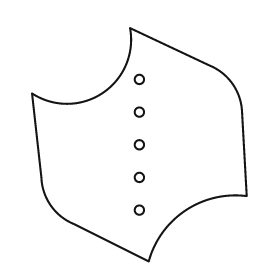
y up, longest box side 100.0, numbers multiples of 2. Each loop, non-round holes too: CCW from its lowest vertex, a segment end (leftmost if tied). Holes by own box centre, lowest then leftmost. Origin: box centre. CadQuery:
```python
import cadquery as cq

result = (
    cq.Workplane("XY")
    .moveTo(4.0, -50.0)
    .threePointArc((20.0, -28.0), (46.0, -22.0))
    .lineTo(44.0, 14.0)
    .threePointArc((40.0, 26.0), (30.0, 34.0))
    .lineTo(-4.0, 50.0)
    .threePointArc((-16.0, 22.0), (-46.0, 22.0))
    .lineTo(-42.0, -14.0)
    .threePointArc((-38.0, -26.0), (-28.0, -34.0))
    .close()
    .moveTo(0.0, -28.0)
    .circle(2.0)
    .moveTo(0.0, -14.0)
    .circle(2.0)
    .moveTo(0.0, 0.0)
    .circle(2.0)
    .moveTo(0.0, 14.0)
    .circle(2.0)
    .moveTo(0.0, 28.0)
    .circle(2.0)
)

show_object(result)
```